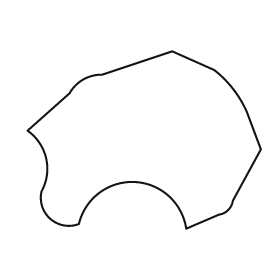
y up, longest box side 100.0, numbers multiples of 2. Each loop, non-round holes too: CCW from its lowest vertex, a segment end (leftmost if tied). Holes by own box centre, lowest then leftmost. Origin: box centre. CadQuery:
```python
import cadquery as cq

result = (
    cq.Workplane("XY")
    .moveTo(18.0, -38.0)
    .lineTo(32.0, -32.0)
    .threePointArc((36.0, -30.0), (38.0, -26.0))
    .lineTo(50.0, -4.0)
    .lineTo(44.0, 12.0)
    .threePointArc((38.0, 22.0), (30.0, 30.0))
    .lineTo(12.0, 38.0)
    .lineTo(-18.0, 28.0)
    .threePointArc((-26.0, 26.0), (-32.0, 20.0))
    .lineTo(-50.0, 4.0)
    .threePointArc((-42.0, -8.0), (-44.0, -22.0))
    .threePointArc((-40.0, -34.0), (-28.0, -36.0))
    .threePointArc((-4.0, -18.0), (18.0, -38.0))
    .close()
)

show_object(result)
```